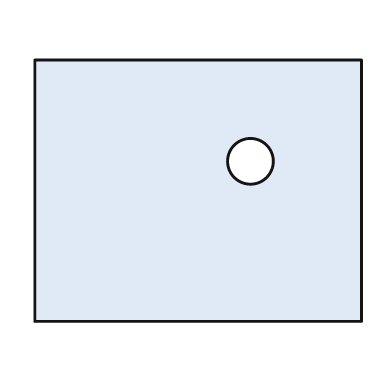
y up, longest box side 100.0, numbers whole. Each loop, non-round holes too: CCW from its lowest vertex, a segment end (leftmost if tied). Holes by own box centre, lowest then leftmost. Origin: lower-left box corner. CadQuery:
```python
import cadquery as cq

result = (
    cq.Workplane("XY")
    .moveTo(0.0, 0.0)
    .lineTo(100.0, 0.0)
    .lineTo(100.0, 80.0)
    .lineTo(0.0, 80.0)
    .close()
    .moveTo(66.0, 49.0)
    .circle(7.0)
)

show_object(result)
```